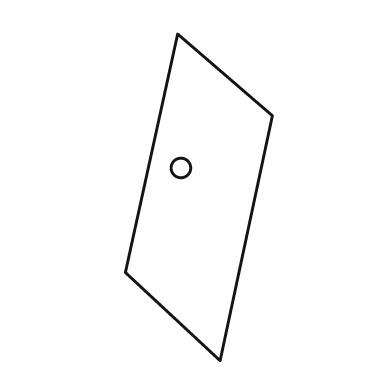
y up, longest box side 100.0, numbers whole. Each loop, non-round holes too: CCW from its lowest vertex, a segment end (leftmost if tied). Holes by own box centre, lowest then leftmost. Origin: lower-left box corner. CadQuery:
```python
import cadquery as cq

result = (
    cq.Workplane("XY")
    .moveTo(29.0, 0.0)
    .lineTo(45.0, 75.0)
    .lineTo(16.0, 100.0)
    .lineTo(0.0, 27.0)
    .close()
    .moveTo(17.0, 59.0)
    .circle(3.0)
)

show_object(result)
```